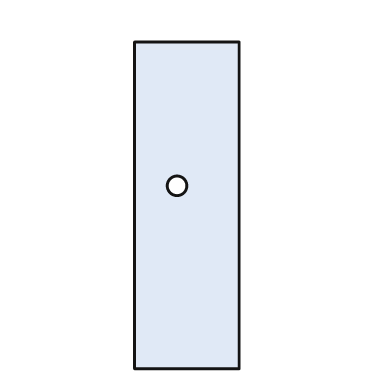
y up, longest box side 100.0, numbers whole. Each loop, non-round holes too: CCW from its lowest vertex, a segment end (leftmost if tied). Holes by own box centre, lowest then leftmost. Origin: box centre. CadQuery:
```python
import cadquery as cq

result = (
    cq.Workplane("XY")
    .moveTo(-16.0, -50.0)
    .lineTo(16.0, -50.0)
    .lineTo(16.0, 50.0)
    .lineTo(-16.0, 50.0)
    .close()
    .moveTo(-3.0, 6.0)
    .circle(3.0)
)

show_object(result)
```